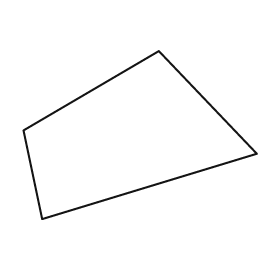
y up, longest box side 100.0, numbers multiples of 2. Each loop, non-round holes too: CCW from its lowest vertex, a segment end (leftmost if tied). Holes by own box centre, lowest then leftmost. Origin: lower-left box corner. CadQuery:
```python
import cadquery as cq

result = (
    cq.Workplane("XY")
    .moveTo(8.0, 0.0)
    .lineTo(100.0, 28.0)
    .lineTo(58.0, 72.0)
    .lineTo(0.0, 38.0)
    .close()
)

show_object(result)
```